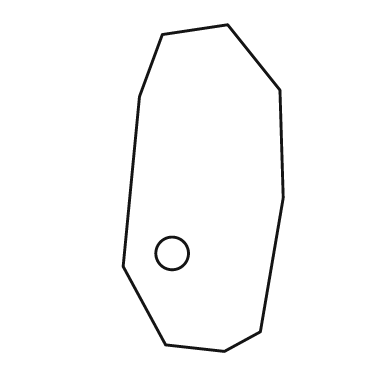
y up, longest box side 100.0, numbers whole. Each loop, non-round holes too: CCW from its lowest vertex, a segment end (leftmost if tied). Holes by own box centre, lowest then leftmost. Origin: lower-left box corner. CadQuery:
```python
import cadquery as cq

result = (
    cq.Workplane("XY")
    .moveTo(31.0, 0.0)
    .lineTo(42.0, 6.0)
    .lineTo(49.0, 47.0)
    .lineTo(48.0, 80.0)
    .lineTo(32.0, 100.0)
    .lineTo(12.0, 97.0)
    .lineTo(5.0, 78.0)
    .lineTo(0.0, 26.0)
    .lineTo(13.0, 2.0)
    .close()
    .moveTo(15.0, 30.0)
    .circle(5.0)
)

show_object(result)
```